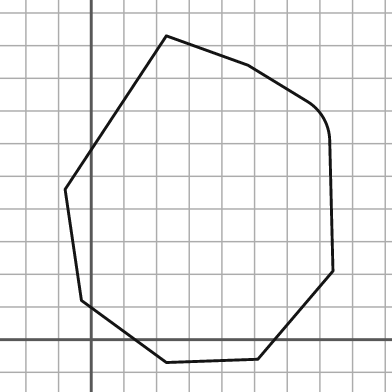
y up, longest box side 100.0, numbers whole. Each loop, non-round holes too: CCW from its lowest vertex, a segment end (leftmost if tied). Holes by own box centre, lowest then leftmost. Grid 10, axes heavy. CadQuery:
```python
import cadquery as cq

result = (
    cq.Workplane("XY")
    .moveTo(23.0, -7.0)
    .lineTo(51.0, -6.0)
    .lineTo(74.0, 21.0)
    .lineTo(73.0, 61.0)
    .threePointArc((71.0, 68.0), (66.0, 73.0))
    .lineTo(48.0, 84.0)
    .lineTo(23.0, 93.0)
    .lineTo(-8.0, 46.0)
    .lineTo(-3.0, 12.0)
    .close()
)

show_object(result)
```